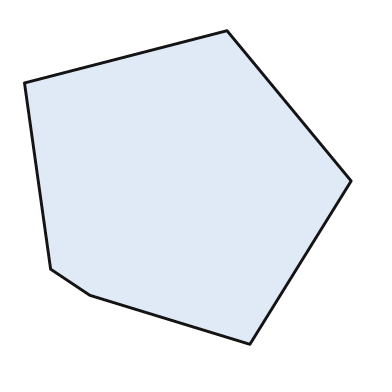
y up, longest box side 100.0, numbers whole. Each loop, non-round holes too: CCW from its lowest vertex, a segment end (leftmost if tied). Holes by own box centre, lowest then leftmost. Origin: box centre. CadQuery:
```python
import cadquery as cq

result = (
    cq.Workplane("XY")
    .moveTo(19.0, -48.0)
    .lineTo(50.0, 2.0)
    .lineTo(12.0, 48.0)
    .lineTo(-50.0, 32.0)
    .lineTo(-42.0, -25.0)
    .lineTo(-30.0, -33.0)
    .close()
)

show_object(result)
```